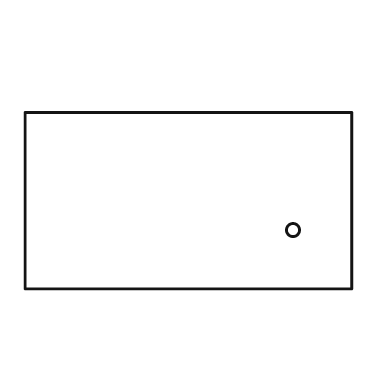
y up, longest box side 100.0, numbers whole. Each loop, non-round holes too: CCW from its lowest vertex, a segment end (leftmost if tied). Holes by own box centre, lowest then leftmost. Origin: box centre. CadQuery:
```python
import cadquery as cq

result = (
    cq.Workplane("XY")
    .moveTo(-50.0, -27.0)
    .lineTo(50.0, -27.0)
    .lineTo(50.0, 27.0)
    .lineTo(-50.0, 27.0)
    .close()
    .moveTo(32.0, -9.0)
    .circle(2.0)
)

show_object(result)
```